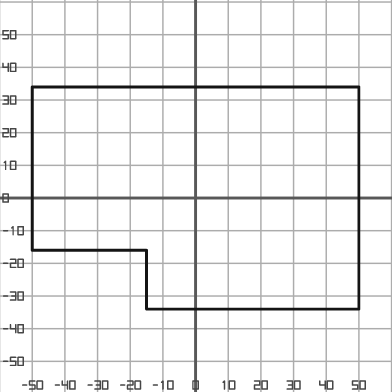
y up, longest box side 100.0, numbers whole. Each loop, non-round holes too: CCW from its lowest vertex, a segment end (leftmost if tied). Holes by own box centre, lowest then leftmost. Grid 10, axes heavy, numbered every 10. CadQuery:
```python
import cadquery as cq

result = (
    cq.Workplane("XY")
    .moveTo(-15.0, -34.0)
    .lineTo(50.0, -34.0)
    .lineTo(50.0, 34.0)
    .lineTo(-50.0, 34.0)
    .lineTo(-50.0, -16.0)
    .lineTo(-15.0, -16.0)
    .close()
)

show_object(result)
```